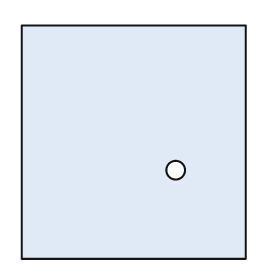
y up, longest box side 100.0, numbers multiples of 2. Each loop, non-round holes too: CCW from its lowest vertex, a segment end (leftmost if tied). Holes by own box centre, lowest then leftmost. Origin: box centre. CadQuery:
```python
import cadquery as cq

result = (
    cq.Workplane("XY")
    .moveTo(-48.0, -50.0)
    .lineTo(48.0, -50.0)
    .lineTo(48.0, 50.0)
    .lineTo(-48.0, 50.0)
    .close()
    .moveTo(18.0, -12.0)
    .circle(4.0)
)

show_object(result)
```